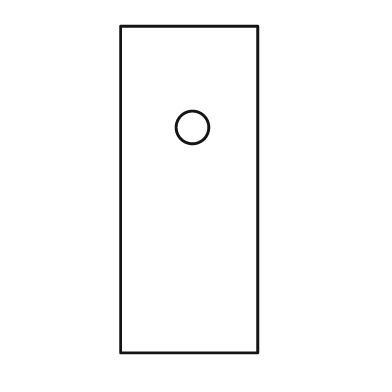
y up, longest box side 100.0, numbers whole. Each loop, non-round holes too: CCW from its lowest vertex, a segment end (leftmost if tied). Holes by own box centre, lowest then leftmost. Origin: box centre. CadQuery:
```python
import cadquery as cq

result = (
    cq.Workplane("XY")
    .moveTo(-21.0, -50.0)
    .lineTo(21.0, -50.0)
    .lineTo(21.0, 50.0)
    .lineTo(-21.0, 50.0)
    .close()
    .moveTo(1.0, 19.0)
    .circle(5.0)
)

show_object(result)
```